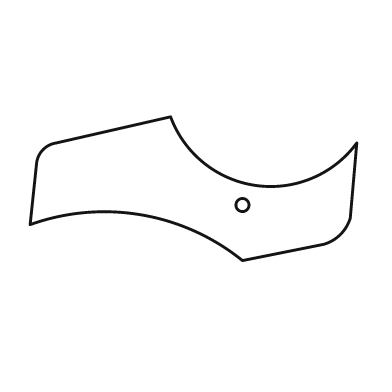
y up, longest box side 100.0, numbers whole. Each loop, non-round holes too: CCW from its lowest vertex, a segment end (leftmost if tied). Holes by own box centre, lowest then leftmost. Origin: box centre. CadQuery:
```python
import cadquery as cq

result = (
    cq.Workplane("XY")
    .moveTo(15.0, -22.0)
    .lineTo(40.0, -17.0)
    .threePointArc((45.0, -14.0), (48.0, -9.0))
    .lineTo(50.0, 14.0)
    .threePointArc((19.0, 1.0), (-7.0, 22.0))
    .lineTo(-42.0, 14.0)
    .threePointArc((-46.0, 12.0), (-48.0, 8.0))
    .lineTo(-50.0, -11.0)
    .threePointArc((-16.0, -8.0), (15.0, -22.0))
    .close()
    .moveTo(15.0, -5.0)
    .circle(2.0)
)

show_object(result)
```